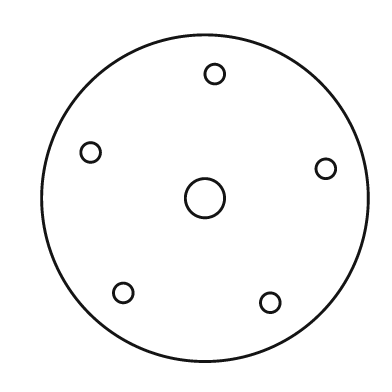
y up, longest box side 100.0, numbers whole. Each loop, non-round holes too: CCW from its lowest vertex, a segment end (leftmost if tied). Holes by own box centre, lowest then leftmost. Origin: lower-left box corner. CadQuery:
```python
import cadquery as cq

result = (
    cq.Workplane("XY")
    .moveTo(50.0, 50.0)
    .circle(50.0)
    .moveTo(70.0, 18.0)
    .circle(3.0)
    .moveTo(25.0, 21.0)
    .circle(3.0)
    .moveTo(50.0, 50.0)
    .circle(6.0)
    .moveTo(87.0, 59.0)
    .circle(3.0)
    .moveTo(15.0, 64.0)
    .circle(3.0)
    .moveTo(53.0, 88.0)
    .circle(3.0)
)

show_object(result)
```